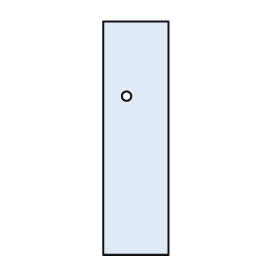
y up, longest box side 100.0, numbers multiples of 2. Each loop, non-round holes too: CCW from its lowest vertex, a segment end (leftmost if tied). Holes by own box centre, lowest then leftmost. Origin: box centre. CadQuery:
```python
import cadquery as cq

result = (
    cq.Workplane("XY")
    .moveTo(-14.0, -50.0)
    .lineTo(14.0, -50.0)
    .lineTo(14.0, 50.0)
    .lineTo(-14.0, 50.0)
    .close()
    .moveTo(-4.0, 18.0)
    .circle(2.0)
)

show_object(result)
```